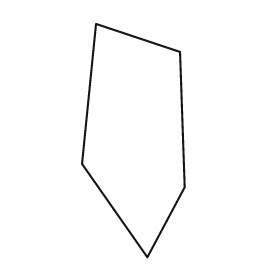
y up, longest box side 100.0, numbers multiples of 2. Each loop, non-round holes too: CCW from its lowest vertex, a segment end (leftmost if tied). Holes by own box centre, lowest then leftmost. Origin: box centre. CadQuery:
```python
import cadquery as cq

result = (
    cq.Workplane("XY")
    .moveTo(6.0, -50.0)
    .lineTo(22.0, -20.0)
    .lineTo(20.0, 38.0)
    .lineTo(-16.0, 50.0)
    .lineTo(-22.0, -10.0)
    .close()
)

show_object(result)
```